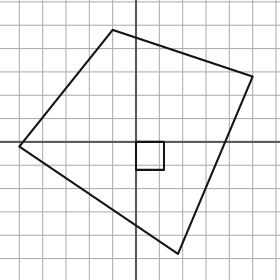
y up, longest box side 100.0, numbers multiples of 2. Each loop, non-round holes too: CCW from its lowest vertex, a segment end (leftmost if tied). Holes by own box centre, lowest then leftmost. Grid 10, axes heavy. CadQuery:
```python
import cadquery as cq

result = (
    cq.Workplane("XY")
    .moveTo(18.0, -48.0)
    .lineTo(50.0, 28.0)
    .lineTo(-10.0, 48.0)
    .lineTo(-50.0, -2.0)
    .close()
    .moveTo(0.0, -12.0)
    .lineTo(12.0, -12.0)
    .lineTo(12.0, 0.0)
    .lineTo(0.0, 0.0)
    .close()
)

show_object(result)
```